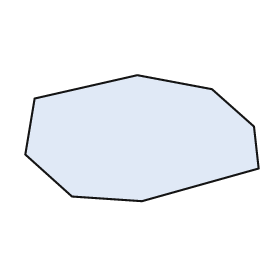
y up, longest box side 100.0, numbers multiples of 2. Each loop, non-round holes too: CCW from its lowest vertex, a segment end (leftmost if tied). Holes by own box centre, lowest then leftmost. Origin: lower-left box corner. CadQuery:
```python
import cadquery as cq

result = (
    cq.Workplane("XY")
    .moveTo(50.0, 0.0)
    .lineTo(100.0, 14.0)
    .lineTo(98.0, 32.0)
    .lineTo(80.0, 48.0)
    .lineTo(48.0, 54.0)
    .lineTo(4.0, 44.0)
    .lineTo(0.0, 20.0)
    .lineTo(20.0, 2.0)
    .close()
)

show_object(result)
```